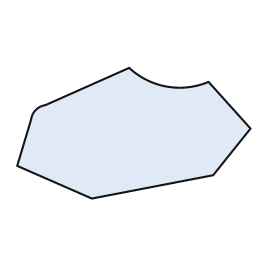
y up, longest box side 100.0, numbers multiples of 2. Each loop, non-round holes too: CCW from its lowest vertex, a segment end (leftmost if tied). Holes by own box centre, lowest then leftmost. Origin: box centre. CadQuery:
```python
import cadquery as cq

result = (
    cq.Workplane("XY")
    .moveTo(-18.0, -28.0)
    .lineTo(34.0, -18.0)
    .lineTo(50.0, 2.0)
    .lineTo(32.0, 22.0)
    .threePointArc((14.0, 20.0), (-2.0, 28.0))
    .lineTo(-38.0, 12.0)
    .threePointArc((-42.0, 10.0), (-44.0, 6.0))
    .lineTo(-50.0, -14.0)
    .close()
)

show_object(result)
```